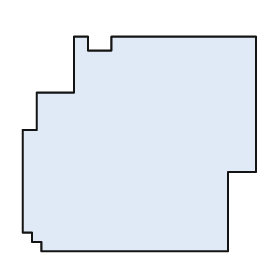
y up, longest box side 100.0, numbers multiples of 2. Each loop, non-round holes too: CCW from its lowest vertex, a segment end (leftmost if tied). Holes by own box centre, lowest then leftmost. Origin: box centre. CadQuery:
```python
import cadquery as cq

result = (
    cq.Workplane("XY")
    .moveTo(-42.0, -46.0)
    .lineTo(38.0, -46.0)
    .lineTo(38.0, -12.0)
    .lineTo(50.0, -12.0)
    .lineTo(50.0, 46.0)
    .lineTo(-12.0, 46.0)
    .lineTo(-12.0, 40.0)
    .lineTo(-22.0, 40.0)
    .lineTo(-22.0, 46.0)
    .lineTo(-28.0, 46.0)
    .lineTo(-28.0, 22.0)
    .lineTo(-44.0, 22.0)
    .lineTo(-44.0, 6.0)
    .lineTo(-50.0, 6.0)
    .lineTo(-50.0, -38.0)
    .lineTo(-46.0, -38.0)
    .lineTo(-46.0, -42.0)
    .lineTo(-42.0, -42.0)
    .close()
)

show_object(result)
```